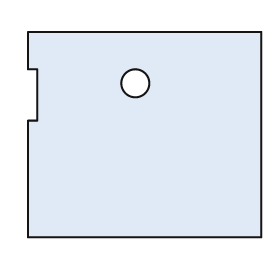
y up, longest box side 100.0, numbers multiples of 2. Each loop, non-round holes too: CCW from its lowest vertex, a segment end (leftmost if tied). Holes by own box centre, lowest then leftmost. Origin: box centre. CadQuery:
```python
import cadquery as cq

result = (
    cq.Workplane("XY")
    .moveTo(-50.0, -44.0)
    .lineTo(50.0, -44.0)
    .lineTo(50.0, 44.0)
    .lineTo(-50.0, 44.0)
    .lineTo(-50.0, 28.0)
    .lineTo(-46.0, 28.0)
    .lineTo(-46.0, 6.0)
    .lineTo(-50.0, 6.0)
    .close()
    .moveTo(-4.0, 22.0)
    .circle(6.0)
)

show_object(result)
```